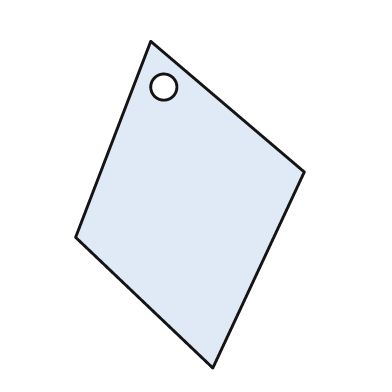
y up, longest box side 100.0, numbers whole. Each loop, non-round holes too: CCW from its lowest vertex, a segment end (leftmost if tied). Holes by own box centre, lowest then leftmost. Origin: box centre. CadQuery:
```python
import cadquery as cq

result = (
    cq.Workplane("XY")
    .moveTo(7.0, -50.0)
    .lineTo(35.0, 10.0)
    .lineTo(-12.0, 50.0)
    .lineTo(-35.0, -10.0)
    .close()
    .moveTo(-8.0, 36.0)
    .circle(4.0)
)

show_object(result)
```